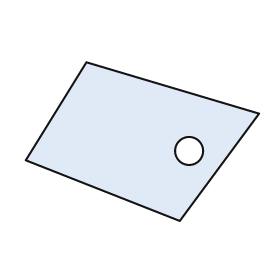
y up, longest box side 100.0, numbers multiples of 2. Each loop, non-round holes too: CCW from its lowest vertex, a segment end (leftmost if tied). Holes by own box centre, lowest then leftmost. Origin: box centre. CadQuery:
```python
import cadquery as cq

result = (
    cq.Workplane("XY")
    .moveTo(16.0, -34.0)
    .lineTo(50.0, 12.0)
    .lineTo(-24.0, 34.0)
    .lineTo(-50.0, -8.0)
    .close()
    .moveTo(20.0, -4.0)
    .circle(6.0)
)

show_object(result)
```